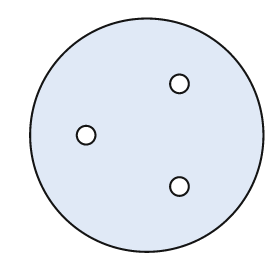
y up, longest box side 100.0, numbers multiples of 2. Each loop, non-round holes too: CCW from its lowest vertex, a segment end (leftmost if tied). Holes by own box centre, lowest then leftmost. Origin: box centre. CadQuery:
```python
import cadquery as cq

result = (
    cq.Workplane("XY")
    .moveTo(0.0, 0.0)
    .circle(50.0)
    .moveTo(14.0, -22.0)
    .circle(4.0)
    .moveTo(-26.0, 0.0)
    .circle(4.0)
    .moveTo(14.0, 22.0)
    .circle(4.0)
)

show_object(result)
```